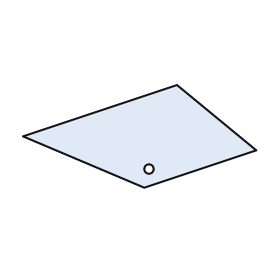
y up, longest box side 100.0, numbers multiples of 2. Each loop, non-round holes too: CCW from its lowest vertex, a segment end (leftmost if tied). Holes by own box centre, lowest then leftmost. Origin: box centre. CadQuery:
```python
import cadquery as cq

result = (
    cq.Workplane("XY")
    .moveTo(2.0, -22.0)
    .lineTo(50.0, -6.0)
    .lineTo(16.0, 22.0)
    .lineTo(-50.0, 0.0)
    .close()
    .moveTo(4.0, -14.0)
    .circle(2.0)
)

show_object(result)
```